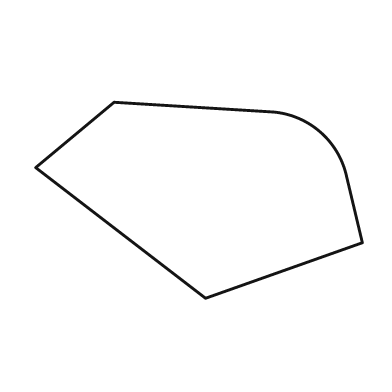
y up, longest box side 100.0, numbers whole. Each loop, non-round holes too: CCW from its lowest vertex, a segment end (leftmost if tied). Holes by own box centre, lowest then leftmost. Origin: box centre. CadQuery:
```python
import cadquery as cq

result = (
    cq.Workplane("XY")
    .moveTo(2.0, -30.0)
    .lineTo(50.0, -13.0)
    .lineTo(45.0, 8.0)
    .threePointArc((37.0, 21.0), (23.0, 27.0))
    .lineTo(-26.0, 30.0)
    .lineTo(-50.0, 10.0)
    .close()
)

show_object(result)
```